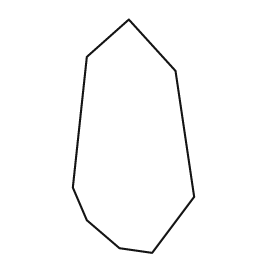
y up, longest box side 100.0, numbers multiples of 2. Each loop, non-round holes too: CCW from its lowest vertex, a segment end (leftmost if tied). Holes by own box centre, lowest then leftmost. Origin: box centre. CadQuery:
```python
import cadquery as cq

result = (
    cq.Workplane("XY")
    .moveTo(8.0, -50.0)
    .lineTo(26.0, -26.0)
    .lineTo(18.0, 28.0)
    .lineTo(-2.0, 50.0)
    .lineTo(-20.0, 34.0)
    .lineTo(-26.0, -22.0)
    .lineTo(-20.0, -36.0)
    .lineTo(-6.0, -48.0)
    .close()
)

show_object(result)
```